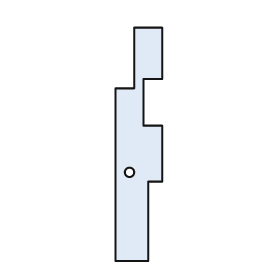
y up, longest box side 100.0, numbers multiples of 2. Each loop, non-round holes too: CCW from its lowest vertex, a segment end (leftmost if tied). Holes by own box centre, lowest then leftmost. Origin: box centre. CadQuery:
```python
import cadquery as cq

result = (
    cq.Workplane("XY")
    .moveTo(-10.0, -50.0)
    .lineTo(4.0, -50.0)
    .lineTo(4.0, -16.0)
    .lineTo(10.0, -16.0)
    .lineTo(10.0, 8.0)
    .lineTo(2.0, 8.0)
    .lineTo(2.0, 28.0)
    .lineTo(10.0, 28.0)
    .lineTo(10.0, 50.0)
    .lineTo(-2.0, 50.0)
    .lineTo(-2.0, 24.0)
    .lineTo(-10.0, 24.0)
    .close()
    .moveTo(-4.0, -12.0)
    .circle(2.0)
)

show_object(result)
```